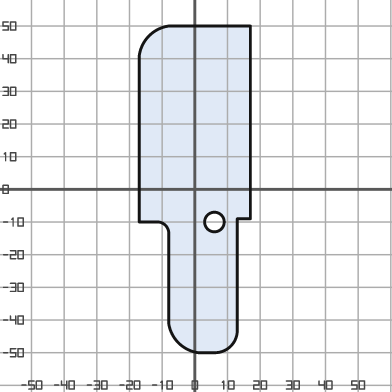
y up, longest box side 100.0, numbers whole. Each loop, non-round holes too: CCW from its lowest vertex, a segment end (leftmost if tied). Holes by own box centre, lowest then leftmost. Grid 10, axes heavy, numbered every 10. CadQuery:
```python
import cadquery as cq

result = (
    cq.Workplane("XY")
    .moveTo(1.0, -50.0)
    .lineTo(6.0, -50.0)
    .threePointArc((11.0, -48.0), (13.0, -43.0))
    .lineTo(13.0, -9.0)
    .lineTo(17.0, -9.0)
    .lineTo(17.0, 50.0)
    .lineTo(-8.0, 50.0)
    .threePointArc((-14.0, 47.0), (-17.0, 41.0))
    .lineTo(-17.0, -10.0)
    .lineTo(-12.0, -10.0)
    .threePointArc((-9.0, -11.0), (-8.0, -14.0))
    .lineTo(-8.0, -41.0)
    .threePointArc((-5.0, -47.0), (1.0, -50.0))
    .close()
    .moveTo(6.0, -10.0)
    .circle(3.0)
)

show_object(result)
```